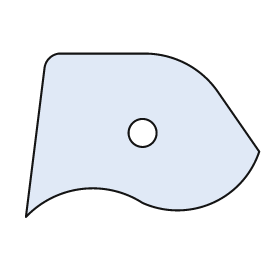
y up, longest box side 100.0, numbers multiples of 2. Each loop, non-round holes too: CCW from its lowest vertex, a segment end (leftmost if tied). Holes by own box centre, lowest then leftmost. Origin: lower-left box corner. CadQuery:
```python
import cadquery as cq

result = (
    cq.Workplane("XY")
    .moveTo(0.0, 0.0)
    .threePointArc((24.0, 12.0), (50.0, 6.0))
    .threePointArc((80.0, 6.0), (100.0, 28.0))
    .lineTo(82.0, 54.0)
    .threePointArc((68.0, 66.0), (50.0, 70.0))
    .lineTo(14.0, 70.0)
    .threePointArc((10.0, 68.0), (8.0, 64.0))
    .close()
    .moveTo(50.0, 36.0)
    .circle(6.0)
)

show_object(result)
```